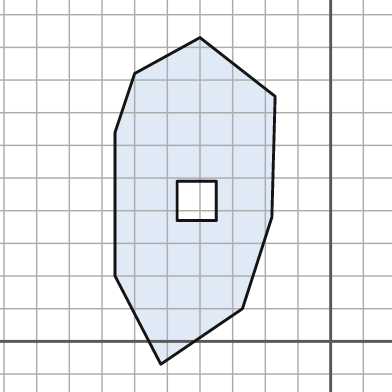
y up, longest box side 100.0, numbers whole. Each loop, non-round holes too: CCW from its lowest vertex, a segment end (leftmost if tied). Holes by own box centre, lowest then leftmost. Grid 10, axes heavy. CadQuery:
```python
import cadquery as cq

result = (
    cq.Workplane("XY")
    .moveTo(-52.0, -7.0)
    .lineTo(-27.0, 10.0)
    .lineTo(-18.0, 38.0)
    .lineTo(-17.0, 75.0)
    .lineTo(-40.0, 93.0)
    .lineTo(-60.0, 82.0)
    .lineTo(-66.0, 64.0)
    .lineTo(-66.0, 20.0)
    .close()
    .moveTo(-47.0, 37.0)
    .lineTo(-35.0, 37.0)
    .lineTo(-35.0, 49.0)
    .lineTo(-47.0, 49.0)
    .close()
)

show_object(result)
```